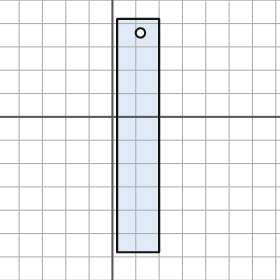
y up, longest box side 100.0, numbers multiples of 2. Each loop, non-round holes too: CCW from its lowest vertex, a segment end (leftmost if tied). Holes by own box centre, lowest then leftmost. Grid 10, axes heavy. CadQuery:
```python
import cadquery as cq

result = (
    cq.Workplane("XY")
    .moveTo(2.0, -58.0)
    .lineTo(20.0, -58.0)
    .lineTo(20.0, 42.0)
    .lineTo(2.0, 42.0)
    .close()
    .moveTo(12.0, 36.0)
    .circle(2.0)
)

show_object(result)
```